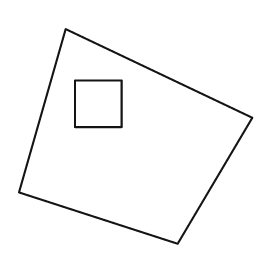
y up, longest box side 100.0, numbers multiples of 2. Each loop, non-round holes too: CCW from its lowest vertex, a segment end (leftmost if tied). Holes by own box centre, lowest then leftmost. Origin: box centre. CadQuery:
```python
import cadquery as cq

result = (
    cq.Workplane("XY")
    .moveTo(18.0, -46.0)
    .lineTo(50.0, 8.0)
    .lineTo(-30.0, 46.0)
    .lineTo(-50.0, -24.0)
    .close()
    .moveTo(-26.0, 4.0)
    .lineTo(-6.0, 4.0)
    .lineTo(-6.0, 24.0)
    .lineTo(-26.0, 24.0)
    .close()
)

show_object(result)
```